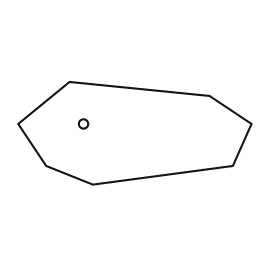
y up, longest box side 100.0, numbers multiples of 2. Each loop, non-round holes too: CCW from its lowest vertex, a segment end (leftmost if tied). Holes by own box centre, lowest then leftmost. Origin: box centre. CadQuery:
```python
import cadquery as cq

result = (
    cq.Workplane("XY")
    .moveTo(-18.0, -22.0)
    .lineTo(42.0, -14.0)
    .lineTo(50.0, 4.0)
    .lineTo(32.0, 16.0)
    .lineTo(-28.0, 22.0)
    .lineTo(-50.0, 4.0)
    .lineTo(-38.0, -14.0)
    .close()
    .moveTo(-22.0, 4.0)
    .circle(2.0)
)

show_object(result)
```